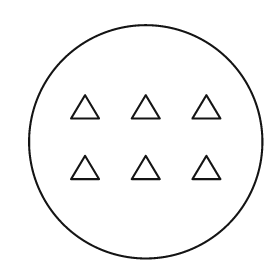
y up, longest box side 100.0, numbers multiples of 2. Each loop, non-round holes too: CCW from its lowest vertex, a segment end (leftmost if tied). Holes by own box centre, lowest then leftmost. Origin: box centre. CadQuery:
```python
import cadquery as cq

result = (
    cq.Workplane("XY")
    .moveTo(0.0, 0.0)
    .circle(50.0)
    .moveTo(-32.0, -16.0)
    .lineTo(-20.0, -16.0)
    .lineTo(-26.0, -6.0)
    .close()
    .moveTo(-6.0, -16.0)
    .lineTo(6.0, -16.0)
    .lineTo(0.0, -6.0)
    .close()
    .moveTo(20.0, -16.0)
    .lineTo(32.0, -16.0)
    .lineTo(26.0, -6.0)
    .close()
    .moveTo(-32.0, 10.0)
    .lineTo(-20.0, 10.0)
    .lineTo(-26.0, 20.0)
    .close()
    .moveTo(-6.0, 10.0)
    .lineTo(6.0, 10.0)
    .lineTo(0.0, 20.0)
    .close()
    .moveTo(20.0, 10.0)
    .lineTo(32.0, 10.0)
    .lineTo(26.0, 20.0)
    .close()
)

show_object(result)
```